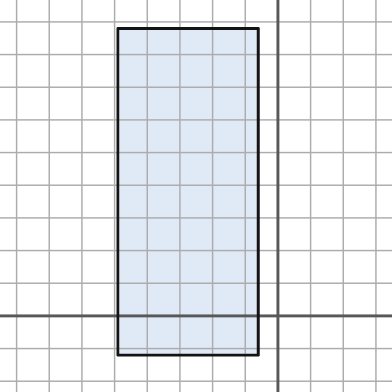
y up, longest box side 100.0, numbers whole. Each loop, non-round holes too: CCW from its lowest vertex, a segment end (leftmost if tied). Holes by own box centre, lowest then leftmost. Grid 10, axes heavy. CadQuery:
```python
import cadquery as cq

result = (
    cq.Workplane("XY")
    .moveTo(-49.0, -12.0)
    .lineTo(-6.0, -12.0)
    .lineTo(-6.0, 88.0)
    .lineTo(-49.0, 88.0)
    .close()
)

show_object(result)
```